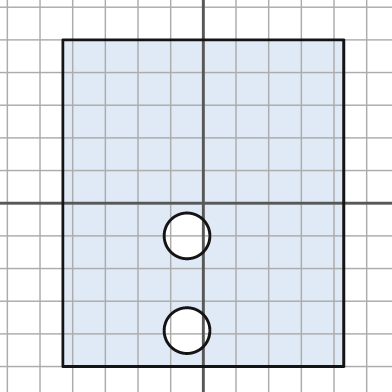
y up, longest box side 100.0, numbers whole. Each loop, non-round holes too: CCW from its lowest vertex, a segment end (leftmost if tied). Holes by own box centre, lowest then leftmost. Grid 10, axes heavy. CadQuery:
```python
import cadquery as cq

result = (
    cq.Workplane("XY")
    .moveTo(-43.0, -50.0)
    .lineTo(43.0, -50.0)
    .lineTo(43.0, 50.0)
    .lineTo(-43.0, 50.0)
    .close()
    .moveTo(-5.0, -39.0)
    .circle(7.0)
    .moveTo(-5.0, -10.0)
    .circle(7.0)
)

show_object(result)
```